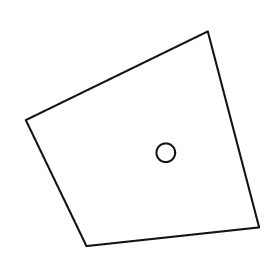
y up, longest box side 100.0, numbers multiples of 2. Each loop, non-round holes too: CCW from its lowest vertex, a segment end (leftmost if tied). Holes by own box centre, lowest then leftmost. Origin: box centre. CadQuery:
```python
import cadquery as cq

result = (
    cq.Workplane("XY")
    .moveTo(-24.0, -46.0)
    .lineTo(50.0, -38.0)
    .lineTo(28.0, 46.0)
    .lineTo(-50.0, 8.0)
    .close()
    .moveTo(10.0, -6.0)
    .circle(4.0)
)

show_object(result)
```